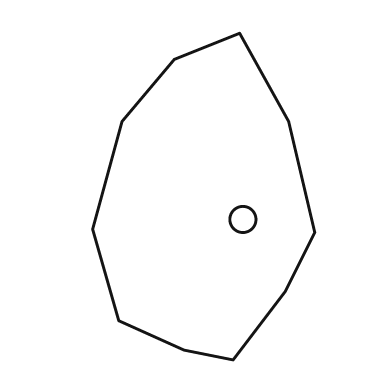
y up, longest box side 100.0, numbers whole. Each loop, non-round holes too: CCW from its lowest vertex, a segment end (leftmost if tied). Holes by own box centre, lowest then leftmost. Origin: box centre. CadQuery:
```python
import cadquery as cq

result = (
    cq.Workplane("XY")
    .moveTo(9.0, -50.0)
    .lineTo(25.0, -29.0)
    .lineTo(34.0, -11.0)
    .lineTo(26.0, 23.0)
    .lineTo(11.0, 50.0)
    .lineTo(-9.0, 42.0)
    .lineTo(-25.0, 23.0)
    .lineTo(-34.0, -10.0)
    .lineTo(-26.0, -38.0)
    .lineTo(-6.0, -47.0)
    .close()
    .moveTo(12.0, -7.0)
    .circle(4.0)
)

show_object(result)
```